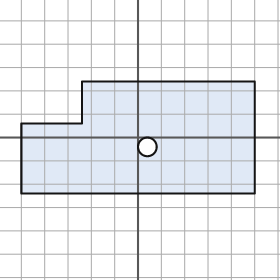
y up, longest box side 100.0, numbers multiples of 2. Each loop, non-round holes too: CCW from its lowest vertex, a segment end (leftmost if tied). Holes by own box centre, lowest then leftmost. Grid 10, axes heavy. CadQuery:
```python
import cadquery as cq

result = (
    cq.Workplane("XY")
    .moveTo(-50.0, -24.0)
    .lineTo(50.0, -24.0)
    .lineTo(50.0, 24.0)
    .lineTo(-24.0, 24.0)
    .lineTo(-24.0, 6.0)
    .lineTo(-50.0, 6.0)
    .close()
    .moveTo(4.0, -4.0)
    .circle(4.0)
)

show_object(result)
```